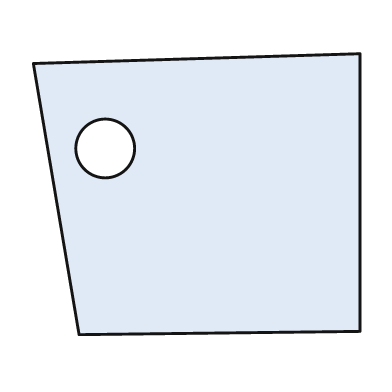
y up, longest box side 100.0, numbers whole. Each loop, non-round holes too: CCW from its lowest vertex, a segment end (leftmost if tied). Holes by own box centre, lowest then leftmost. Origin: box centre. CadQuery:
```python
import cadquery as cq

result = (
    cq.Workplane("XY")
    .moveTo(-36.0, -43.0)
    .lineTo(50.0, -42.0)
    .lineTo(50.0, 43.0)
    .lineTo(-50.0, 40.0)
    .close()
    .moveTo(-28.0, 14.0)
    .circle(9.0)
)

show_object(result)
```